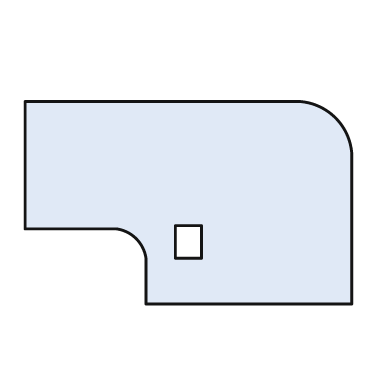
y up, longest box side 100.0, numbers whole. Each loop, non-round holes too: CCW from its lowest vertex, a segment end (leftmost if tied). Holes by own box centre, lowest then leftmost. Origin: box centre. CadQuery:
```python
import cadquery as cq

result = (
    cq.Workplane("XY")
    .moveTo(-13.0, -31.0)
    .lineTo(50.0, -31.0)
    .lineTo(50.0, 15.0)
    .threePointArc((45.0, 26.0), (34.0, 31.0))
    .lineTo(-50.0, 31.0)
    .lineTo(-50.0, -8.0)
    .lineTo(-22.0, -8.0)
    .threePointArc((-16.0, -11.0), (-13.0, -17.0))
    .close()
    .moveTo(-4.0, -17.0)
    .lineTo(4.0, -17.0)
    .lineTo(4.0, -7.0)
    .lineTo(-4.0, -7.0)
    .close()
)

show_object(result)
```